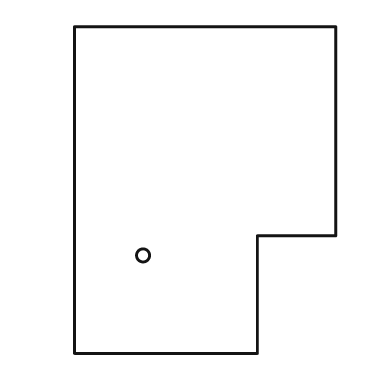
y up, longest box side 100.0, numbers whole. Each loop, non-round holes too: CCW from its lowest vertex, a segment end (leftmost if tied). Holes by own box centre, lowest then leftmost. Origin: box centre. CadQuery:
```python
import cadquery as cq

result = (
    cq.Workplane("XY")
    .moveTo(-40.0, -50.0)
    .lineTo(16.0, -50.0)
    .lineTo(16.0, -14.0)
    .lineTo(40.0, -14.0)
    .lineTo(40.0, 50.0)
    .lineTo(-40.0, 50.0)
    .close()
    .moveTo(-19.0, -20.0)
    .circle(2.0)
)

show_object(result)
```